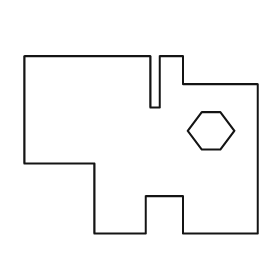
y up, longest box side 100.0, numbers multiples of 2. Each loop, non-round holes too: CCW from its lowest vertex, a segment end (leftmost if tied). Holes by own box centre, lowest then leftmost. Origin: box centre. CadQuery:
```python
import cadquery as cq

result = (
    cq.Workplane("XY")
    .moveTo(-20.0, -38.0)
    .lineTo(2.0, -38.0)
    .lineTo(2.0, -22.0)
    .lineTo(18.0, -22.0)
    .lineTo(18.0, -38.0)
    .lineTo(50.0, -38.0)
    .lineTo(50.0, 26.0)
    .lineTo(18.0, 26.0)
    .lineTo(18.0, 38.0)
    .lineTo(8.0, 38.0)
    .lineTo(8.0, 16.0)
    .lineTo(4.0, 16.0)
    .lineTo(4.0, 38.0)
    .lineTo(-50.0, 38.0)
    .lineTo(-50.0, -8.0)
    .lineTo(-20.0, -8.0)
    .close()
    .moveTo(26.0, -2.0)
    .lineTo(34.0, -2.0)
    .lineTo(40.0, 6.0)
    .lineTo(34.0, 14.0)
    .lineTo(26.0, 14.0)
    .lineTo(20.0, 6.0)
    .close()
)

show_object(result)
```